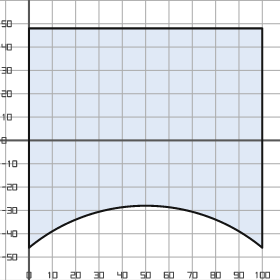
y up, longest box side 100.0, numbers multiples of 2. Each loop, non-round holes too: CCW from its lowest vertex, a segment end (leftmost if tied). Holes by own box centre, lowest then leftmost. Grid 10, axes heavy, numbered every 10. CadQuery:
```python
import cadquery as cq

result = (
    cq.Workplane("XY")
    .moveTo(0.0, -46.0)
    .threePointArc((50.0, -28.0), (100.0, -46.0))
    .lineTo(100.0, 48.0)
    .lineTo(0.0, 48.0)
    .close()
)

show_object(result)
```